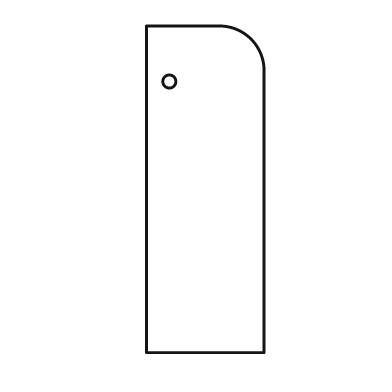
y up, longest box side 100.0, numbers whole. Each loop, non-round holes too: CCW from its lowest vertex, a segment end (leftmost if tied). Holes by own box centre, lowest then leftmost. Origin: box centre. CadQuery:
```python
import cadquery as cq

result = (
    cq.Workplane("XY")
    .moveTo(-18.0, -50.0)
    .lineTo(18.0, -50.0)
    .lineTo(18.0, 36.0)
    .threePointArc((14.0, 46.0), (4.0, 50.0))
    .lineTo(-18.0, 50.0)
    .close()
    .moveTo(-11.0, 33.0)
    .circle(2.0)
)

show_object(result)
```